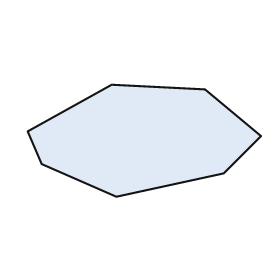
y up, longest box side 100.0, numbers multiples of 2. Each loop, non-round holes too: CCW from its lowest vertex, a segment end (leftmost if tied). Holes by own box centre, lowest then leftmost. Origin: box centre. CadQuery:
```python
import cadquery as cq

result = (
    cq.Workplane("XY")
    .moveTo(-12.0, -24.0)
    .lineTo(34.0, -14.0)
    .lineTo(50.0, 2.0)
    .lineTo(26.0, 22.0)
    .lineTo(-14.0, 24.0)
    .lineTo(-50.0, 4.0)
    .lineTo(-44.0, -10.0)
    .close()
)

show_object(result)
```